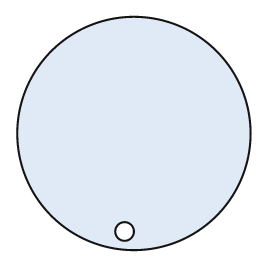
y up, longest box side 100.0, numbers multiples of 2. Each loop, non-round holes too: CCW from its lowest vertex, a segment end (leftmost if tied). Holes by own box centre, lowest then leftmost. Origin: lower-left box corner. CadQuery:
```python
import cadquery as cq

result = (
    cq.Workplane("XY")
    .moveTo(50.0, 50.0)
    .circle(50.0)
    .moveTo(46.0, 8.0)
    .circle(4.0)
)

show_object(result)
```